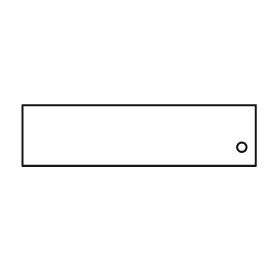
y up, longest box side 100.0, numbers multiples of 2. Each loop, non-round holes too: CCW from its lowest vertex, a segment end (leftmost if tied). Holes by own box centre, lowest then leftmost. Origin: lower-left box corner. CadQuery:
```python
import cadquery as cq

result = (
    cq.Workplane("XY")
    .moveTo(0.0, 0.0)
    .lineTo(100.0, 0.0)
    .lineTo(100.0, 26.0)
    .lineTo(0.0, 26.0)
    .close()
    .moveTo(94.0, 8.0)
    .circle(2.0)
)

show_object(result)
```